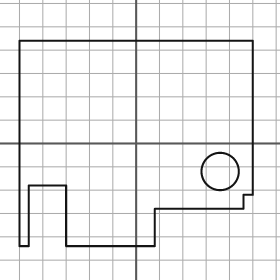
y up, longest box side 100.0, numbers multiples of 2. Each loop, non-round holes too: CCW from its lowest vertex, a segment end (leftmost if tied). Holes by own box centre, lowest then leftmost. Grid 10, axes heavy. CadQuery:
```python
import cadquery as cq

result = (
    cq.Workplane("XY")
    .moveTo(-50.0, -44.0)
    .lineTo(-46.0, -44.0)
    .lineTo(-46.0, -18.0)
    .lineTo(-30.0, -18.0)
    .lineTo(-30.0, -44.0)
    .lineTo(8.0, -44.0)
    .lineTo(8.0, -28.0)
    .lineTo(46.0, -28.0)
    .lineTo(46.0, -22.0)
    .lineTo(50.0, -22.0)
    .lineTo(50.0, 44.0)
    .lineTo(-50.0, 44.0)
    .close()
    .moveTo(36.0, -12.0)
    .circle(8.0)
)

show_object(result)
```